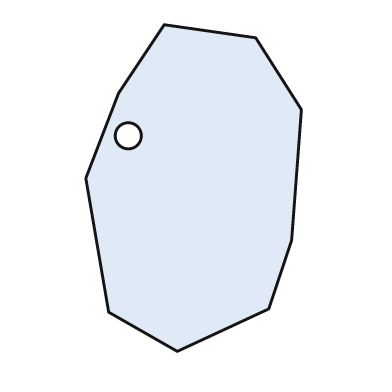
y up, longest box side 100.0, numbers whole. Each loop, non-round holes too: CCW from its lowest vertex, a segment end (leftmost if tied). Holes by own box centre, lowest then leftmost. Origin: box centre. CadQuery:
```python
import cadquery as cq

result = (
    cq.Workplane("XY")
    .moveTo(-5.0, -50.0)
    .lineTo(23.0, -37.0)
    .lineTo(30.0, -16.0)
    .lineTo(33.0, 24.0)
    .lineTo(19.0, 46.0)
    .lineTo(-9.0, 50.0)
    .lineTo(-23.0, 29.0)
    .lineTo(-33.0, 3.0)
    .lineTo(-26.0, -38.0)
    .close()
    .moveTo(-20.0, 16.0)
    .circle(4.0)
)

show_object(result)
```